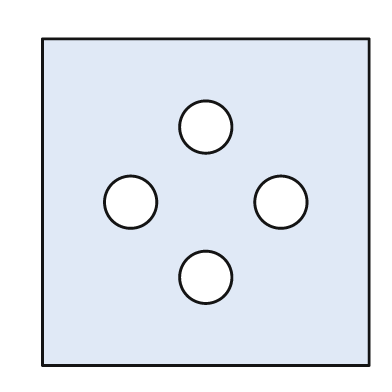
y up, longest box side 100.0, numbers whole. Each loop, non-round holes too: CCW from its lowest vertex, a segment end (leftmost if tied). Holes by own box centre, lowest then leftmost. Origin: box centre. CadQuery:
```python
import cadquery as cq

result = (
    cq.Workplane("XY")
    .moveTo(-50.0, -50.0)
    .lineTo(50.0, -50.0)
    .lineTo(50.0, 50.0)
    .lineTo(-50.0, 50.0)
    .close()
    .moveTo(0.0, -23.0)
    .circle(8.0)
    .moveTo(-23.0, 0.0)
    .circle(8.0)
    .moveTo(23.0, 0.0)
    .circle(8.0)
    .moveTo(0.0, 23.0)
    .circle(8.0)
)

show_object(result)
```